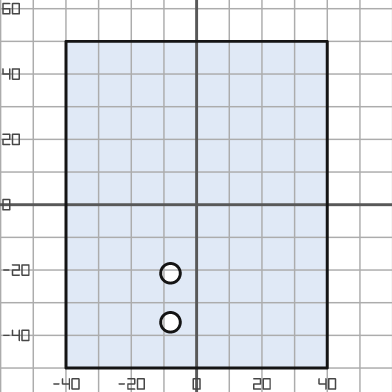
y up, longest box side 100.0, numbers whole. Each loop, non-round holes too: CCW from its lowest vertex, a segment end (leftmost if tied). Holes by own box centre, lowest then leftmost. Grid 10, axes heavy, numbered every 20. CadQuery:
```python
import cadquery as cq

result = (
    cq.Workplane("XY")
    .moveTo(-40.0, -50.0)
    .lineTo(40.0, -50.0)
    .lineTo(40.0, 50.0)
    .lineTo(-40.0, 50.0)
    .close()
    .moveTo(-8.0, -36.0)
    .circle(3.0)
    .moveTo(-8.0, -21.0)
    .circle(3.0)
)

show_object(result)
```